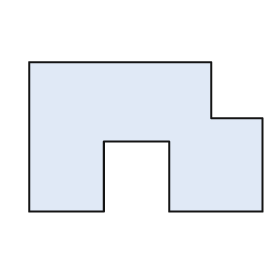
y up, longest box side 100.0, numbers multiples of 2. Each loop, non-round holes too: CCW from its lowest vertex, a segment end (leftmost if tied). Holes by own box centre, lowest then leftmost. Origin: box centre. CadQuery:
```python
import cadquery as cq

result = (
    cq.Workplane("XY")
    .moveTo(-50.0, -32.0)
    .lineTo(-18.0, -32.0)
    .lineTo(-18.0, -2.0)
    .lineTo(10.0, -2.0)
    .lineTo(10.0, -32.0)
    .lineTo(50.0, -32.0)
    .lineTo(50.0, 8.0)
    .lineTo(28.0, 8.0)
    .lineTo(28.0, 32.0)
    .lineTo(-50.0, 32.0)
    .close()
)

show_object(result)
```